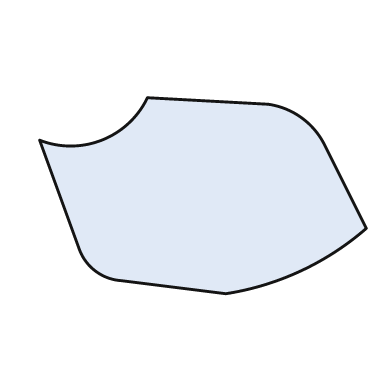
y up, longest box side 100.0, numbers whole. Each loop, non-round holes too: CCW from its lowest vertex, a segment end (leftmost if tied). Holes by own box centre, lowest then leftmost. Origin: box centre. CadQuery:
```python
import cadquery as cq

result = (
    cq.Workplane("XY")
    .moveTo(7.0, -30.0)
    .threePointArc((30.0, -23.0), (50.0, -10.0))
    .lineTo(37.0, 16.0)
    .threePointArc((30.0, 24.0), (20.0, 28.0))
    .lineTo(-17.0, 30.0)
    .threePointArc((-31.0, 17.0), (-50.0, 17.0))
    .lineTo(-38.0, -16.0)
    .threePointArc((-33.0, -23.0), (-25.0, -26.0))
    .close()
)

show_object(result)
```